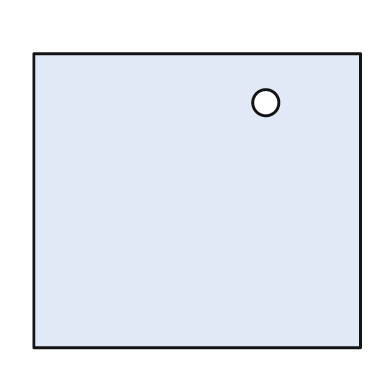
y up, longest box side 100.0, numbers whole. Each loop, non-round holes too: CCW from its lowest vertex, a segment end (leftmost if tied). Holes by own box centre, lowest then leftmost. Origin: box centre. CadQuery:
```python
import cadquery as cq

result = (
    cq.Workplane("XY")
    .moveTo(-50.0, -45.0)
    .lineTo(50.0, -45.0)
    .lineTo(50.0, 45.0)
    .lineTo(-50.0, 45.0)
    .close()
    .moveTo(21.0, 30.0)
    .circle(4.0)
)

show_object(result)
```